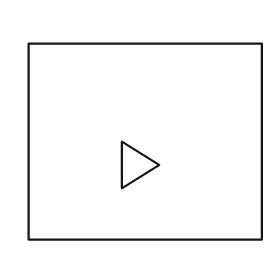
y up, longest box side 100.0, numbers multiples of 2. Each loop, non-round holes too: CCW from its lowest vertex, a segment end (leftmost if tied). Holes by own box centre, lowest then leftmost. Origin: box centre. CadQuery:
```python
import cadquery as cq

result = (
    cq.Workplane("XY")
    .moveTo(-50.0, -42.0)
    .lineTo(50.0, -42.0)
    .lineTo(50.0, 42.0)
    .lineTo(-50.0, 42.0)
    .close()
    .moveTo(-10.0, -20.0)
    .lineTo(6.0, -10.0)
    .lineTo(-10.0, 0.0)
    .close()
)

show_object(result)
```